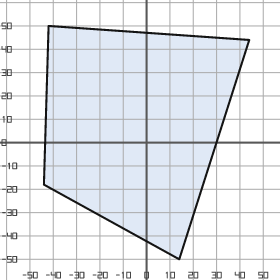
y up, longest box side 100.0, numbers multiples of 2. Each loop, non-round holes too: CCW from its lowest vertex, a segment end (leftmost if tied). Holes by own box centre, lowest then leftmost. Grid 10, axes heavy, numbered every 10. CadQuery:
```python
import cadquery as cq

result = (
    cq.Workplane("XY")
    .moveTo(14.0, -50.0)
    .lineTo(44.0, 44.0)
    .lineTo(-42.0, 50.0)
    .lineTo(-44.0, -18.0)
    .close()
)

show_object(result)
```